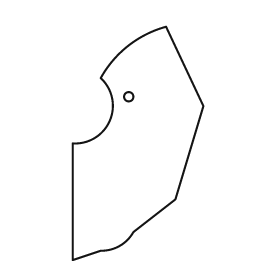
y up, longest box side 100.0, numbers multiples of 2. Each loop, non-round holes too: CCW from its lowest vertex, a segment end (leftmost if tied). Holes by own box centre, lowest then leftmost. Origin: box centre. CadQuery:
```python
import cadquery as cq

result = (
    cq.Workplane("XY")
    .moveTo(-28.0, -50.0)
    .lineTo(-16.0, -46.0)
    .threePointArc((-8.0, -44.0), (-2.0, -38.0))
    .lineTo(16.0, -24.0)
    .lineTo(28.0, 16.0)
    .lineTo(12.0, 50.0)
    .threePointArc((-4.0, 42.0), (-16.0, 28.0))
    .threePointArc((-12.0, 10.0), (-28.0, 0.0))
    .close()
    .moveTo(-4.0, 20.0)
    .circle(2.0)
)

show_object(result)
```